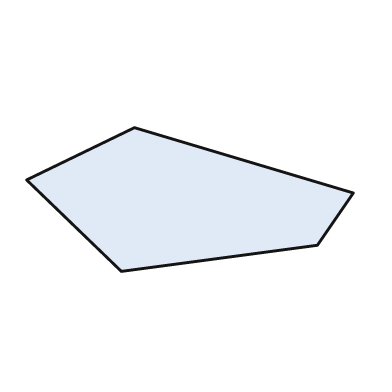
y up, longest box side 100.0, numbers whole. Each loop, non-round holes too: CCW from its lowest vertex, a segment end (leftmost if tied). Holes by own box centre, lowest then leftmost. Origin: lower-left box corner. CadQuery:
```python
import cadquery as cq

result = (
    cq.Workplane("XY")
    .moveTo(29.0, 0.0)
    .lineTo(89.0, 8.0)
    .lineTo(100.0, 24.0)
    .lineTo(33.0, 44.0)
    .lineTo(0.0, 28.0)
    .close()
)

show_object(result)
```